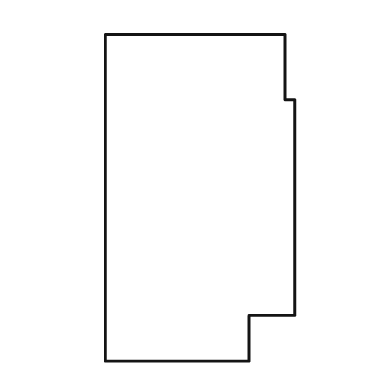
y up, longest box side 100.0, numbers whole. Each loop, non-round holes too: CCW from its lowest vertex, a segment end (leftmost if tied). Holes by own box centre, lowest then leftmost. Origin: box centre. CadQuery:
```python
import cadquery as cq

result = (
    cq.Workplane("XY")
    .moveTo(-29.0, -50.0)
    .lineTo(15.0, -50.0)
    .lineTo(15.0, -36.0)
    .lineTo(29.0, -36.0)
    .lineTo(29.0, 30.0)
    .lineTo(26.0, 30.0)
    .lineTo(26.0, 50.0)
    .lineTo(-29.0, 50.0)
    .close()
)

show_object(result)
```